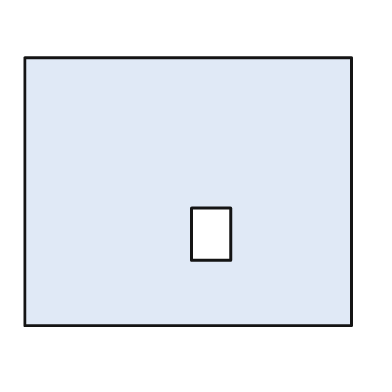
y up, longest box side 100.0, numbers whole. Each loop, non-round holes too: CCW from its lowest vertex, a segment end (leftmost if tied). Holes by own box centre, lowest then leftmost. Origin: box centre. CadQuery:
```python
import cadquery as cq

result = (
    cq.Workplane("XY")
    .moveTo(-50.0, -41.0)
    .lineTo(50.0, -41.0)
    .lineTo(50.0, 41.0)
    .lineTo(-50.0, 41.0)
    .close()
    .moveTo(1.0, -21.0)
    .lineTo(13.0, -21.0)
    .lineTo(13.0, -5.0)
    .lineTo(1.0, -5.0)
    .close()
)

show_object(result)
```